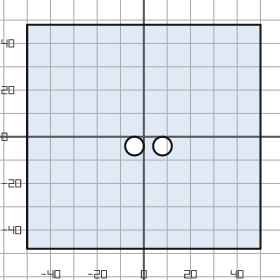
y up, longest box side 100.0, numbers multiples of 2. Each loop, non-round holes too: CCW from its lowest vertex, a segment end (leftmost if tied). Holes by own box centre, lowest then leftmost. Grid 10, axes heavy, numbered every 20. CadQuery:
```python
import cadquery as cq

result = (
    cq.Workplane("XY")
    .moveTo(-50.0, -48.0)
    .lineTo(50.0, -48.0)
    .lineTo(50.0, 48.0)
    .lineTo(-50.0, 48.0)
    .close()
    .moveTo(-4.0, -4.0)
    .circle(4.0)
    .moveTo(8.0, -4.0)
    .circle(4.0)
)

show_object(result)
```